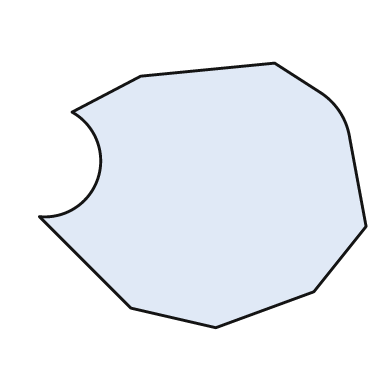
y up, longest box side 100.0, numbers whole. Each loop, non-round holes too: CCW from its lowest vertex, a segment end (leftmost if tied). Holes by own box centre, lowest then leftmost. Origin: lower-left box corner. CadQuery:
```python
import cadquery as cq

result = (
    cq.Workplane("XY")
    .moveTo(54.0, 0.0)
    .lineTo(84.0, 11.0)
    .lineTo(100.0, 31.0)
    .lineTo(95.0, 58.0)
    .threePointArc((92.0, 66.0), (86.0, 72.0))
    .lineTo(72.0, 81.0)
    .lineTo(31.0, 77.0)
    .lineTo(10.0, 66.0)
    .threePointArc((18.0, 46.0), (0.0, 34.0))
    .lineTo(28.0, 6.0)
    .close()
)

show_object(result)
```